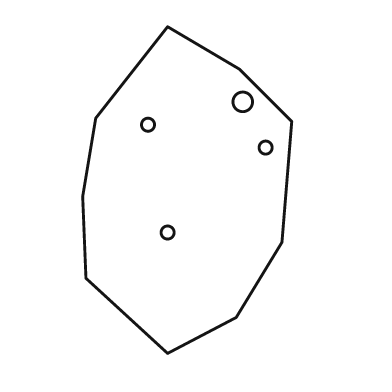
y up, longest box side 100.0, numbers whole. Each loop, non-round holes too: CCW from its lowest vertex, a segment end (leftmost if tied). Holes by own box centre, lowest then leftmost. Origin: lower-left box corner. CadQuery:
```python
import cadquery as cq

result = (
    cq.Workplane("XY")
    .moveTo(26.0, 0.0)
    .lineTo(47.0, 11.0)
    .lineTo(61.0, 34.0)
    .lineTo(64.0, 71.0)
    .lineTo(48.0, 87.0)
    .lineTo(26.0, 100.0)
    .lineTo(4.0, 72.0)
    .lineTo(0.0, 48.0)
    .lineTo(1.0, 23.0)
    .close()
    .moveTo(26.0, 37.0)
    .circle(2.0)
    .moveTo(56.0, 63.0)
    .circle(2.0)
    .moveTo(20.0, 70.0)
    .circle(2.0)
    .moveTo(49.0, 77.0)
    .circle(3.0)
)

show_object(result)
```